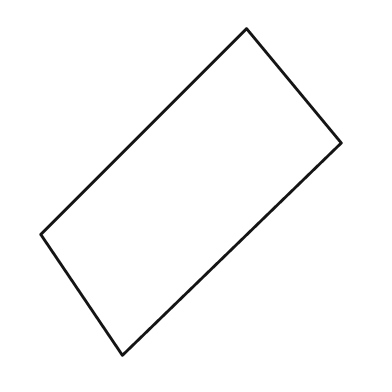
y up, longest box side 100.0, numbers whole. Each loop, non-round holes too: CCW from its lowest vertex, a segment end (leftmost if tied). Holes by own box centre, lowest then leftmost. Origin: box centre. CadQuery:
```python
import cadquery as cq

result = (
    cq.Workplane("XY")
    .moveTo(-21.0, -50.0)
    .lineTo(46.0, 15.0)
    .lineTo(17.0, 50.0)
    .lineTo(-46.0, -13.0)
    .close()
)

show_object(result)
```